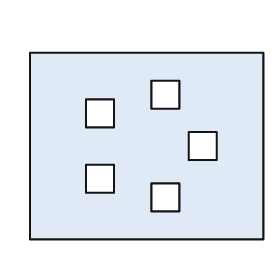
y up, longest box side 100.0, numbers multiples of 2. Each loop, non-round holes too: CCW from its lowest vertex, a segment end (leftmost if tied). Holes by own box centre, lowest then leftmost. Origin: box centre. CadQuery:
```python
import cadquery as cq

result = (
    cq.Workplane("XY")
    .moveTo(-50.0, -40.0)
    .lineTo(50.0, -40.0)
    .lineTo(50.0, 40.0)
    .lineTo(-50.0, 40.0)
    .close()
    .moveTo(2.0, -28.0)
    .lineTo(14.0, -28.0)
    .lineTo(14.0, -16.0)
    .lineTo(2.0, -16.0)
    .close()
    .moveTo(-26.0, -20.0)
    .lineTo(-14.0, -20.0)
    .lineTo(-14.0, -8.0)
    .lineTo(-26.0, -8.0)
    .close()
    .moveTo(18.0, -6.0)
    .lineTo(30.0, -6.0)
    .lineTo(30.0, 6.0)
    .lineTo(18.0, 6.0)
    .close()
    .moveTo(-26.0, 8.0)
    .lineTo(-14.0, 8.0)
    .lineTo(-14.0, 20.0)
    .lineTo(-26.0, 20.0)
    .close()
    .moveTo(2.0, 16.0)
    .lineTo(14.0, 16.0)
    .lineTo(14.0, 28.0)
    .lineTo(2.0, 28.0)
    .close()
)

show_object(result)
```